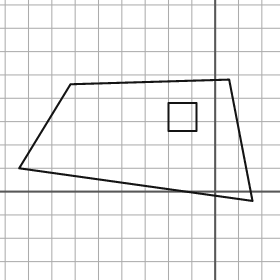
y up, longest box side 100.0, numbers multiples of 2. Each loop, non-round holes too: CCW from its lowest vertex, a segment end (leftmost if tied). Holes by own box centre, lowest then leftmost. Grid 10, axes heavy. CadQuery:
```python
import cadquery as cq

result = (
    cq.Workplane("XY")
    .moveTo(16.0, -4.0)
    .lineTo(6.0, 48.0)
    .lineTo(-62.0, 46.0)
    .lineTo(-84.0, 10.0)
    .close()
    .moveTo(-20.0, 26.0)
    .lineTo(-8.0, 26.0)
    .lineTo(-8.0, 38.0)
    .lineTo(-20.0, 38.0)
    .close()
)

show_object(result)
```